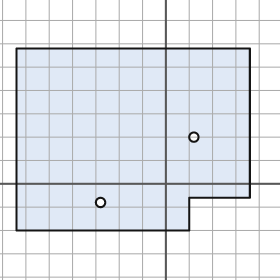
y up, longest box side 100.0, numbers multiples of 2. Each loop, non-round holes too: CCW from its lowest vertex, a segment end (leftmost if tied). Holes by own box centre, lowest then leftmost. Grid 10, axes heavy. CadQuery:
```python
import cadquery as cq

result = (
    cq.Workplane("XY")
    .moveTo(-64.0, -20.0)
    .lineTo(10.0, -20.0)
    .lineTo(10.0, -6.0)
    .lineTo(36.0, -6.0)
    .lineTo(36.0, 58.0)
    .lineTo(-64.0, 58.0)
    .close()
    .moveTo(-28.0, -8.0)
    .circle(2.0)
    .moveTo(12.0, 20.0)
    .circle(2.0)
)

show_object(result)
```